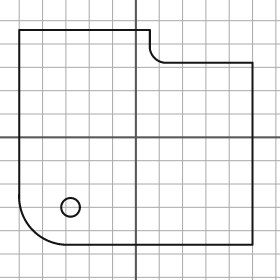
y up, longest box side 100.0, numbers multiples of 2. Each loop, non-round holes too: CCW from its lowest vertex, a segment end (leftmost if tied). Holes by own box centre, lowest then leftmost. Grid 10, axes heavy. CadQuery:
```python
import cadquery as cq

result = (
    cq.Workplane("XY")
    .moveTo(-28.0, -46.0)
    .lineTo(50.0, -46.0)
    .lineTo(50.0, 32.0)
    .lineTo(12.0, 32.0)
    .threePointArc((8.0, 34.0), (6.0, 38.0))
    .lineTo(6.0, 46.0)
    .lineTo(-50.0, 46.0)
    .lineTo(-50.0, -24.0)
    .threePointArc((-44.0, -40.0), (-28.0, -46.0))
    .close()
    .moveTo(-28.0, -30.0)
    .circle(4.0)
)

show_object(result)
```